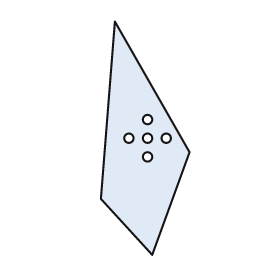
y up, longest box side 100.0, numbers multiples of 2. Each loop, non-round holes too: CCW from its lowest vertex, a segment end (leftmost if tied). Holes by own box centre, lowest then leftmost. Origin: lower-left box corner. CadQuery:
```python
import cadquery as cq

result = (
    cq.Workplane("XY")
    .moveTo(22.0, 0.0)
    .lineTo(38.0, 44.0)
    .lineTo(6.0, 100.0)
    .lineTo(0.0, 24.0)
    .close()
    .moveTo(20.0, 42.0)
    .circle(2.0)
    .moveTo(12.0, 50.0)
    .circle(2.0)
    .moveTo(20.0, 50.0)
    .circle(2.0)
    .moveTo(28.0, 50.0)
    .circle(2.0)
    .moveTo(20.0, 58.0)
    .circle(2.0)
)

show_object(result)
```